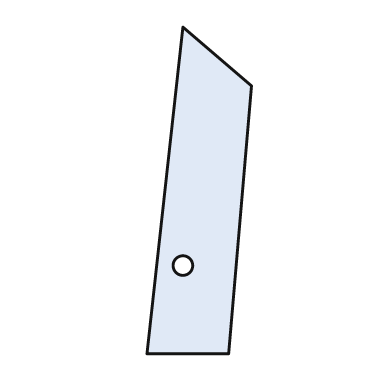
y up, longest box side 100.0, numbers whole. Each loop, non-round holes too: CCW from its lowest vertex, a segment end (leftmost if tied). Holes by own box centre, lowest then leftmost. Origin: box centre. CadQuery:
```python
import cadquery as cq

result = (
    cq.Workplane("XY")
    .moveTo(-16.0, -50.0)
    .lineTo(9.0, -50.0)
    .lineTo(16.0, 32.0)
    .lineTo(-5.0, 50.0)
    .close()
    .moveTo(-5.0, -23.0)
    .circle(3.0)
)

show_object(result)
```